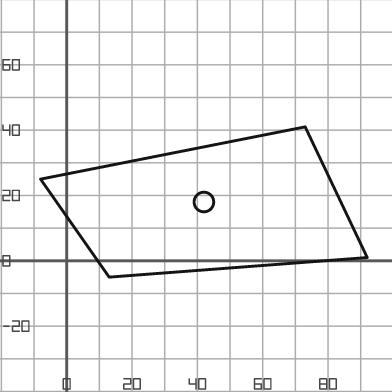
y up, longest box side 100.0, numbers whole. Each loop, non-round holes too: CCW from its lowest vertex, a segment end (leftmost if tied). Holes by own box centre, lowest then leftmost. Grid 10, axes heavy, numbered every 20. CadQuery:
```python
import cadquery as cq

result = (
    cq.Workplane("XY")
    .moveTo(13.0, -5.0)
    .lineTo(92.0, 1.0)
    .lineTo(73.0, 41.0)
    .lineTo(-8.0, 25.0)
    .close()
    .moveTo(42.0, 18.0)
    .circle(3.0)
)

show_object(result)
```